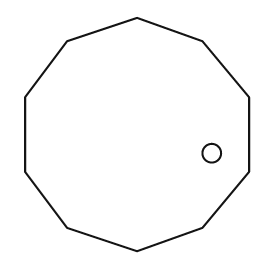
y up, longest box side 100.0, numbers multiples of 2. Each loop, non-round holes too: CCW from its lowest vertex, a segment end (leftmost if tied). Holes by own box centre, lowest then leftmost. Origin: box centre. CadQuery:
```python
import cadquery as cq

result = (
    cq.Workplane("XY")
    .moveTo(0.0, -50.0)
    .lineTo(28.0, -40.0)
    .lineTo(48.0, -16.0)
    .lineTo(48.0, 16.0)
    .lineTo(28.0, 40.0)
    .lineTo(0.0, 50.0)
    .lineTo(-30.0, 40.0)
    .lineTo(-48.0, 16.0)
    .lineTo(-48.0, -16.0)
    .lineTo(-30.0, -40.0)
    .close()
    .moveTo(32.0, -8.0)
    .circle(4.0)
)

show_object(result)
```